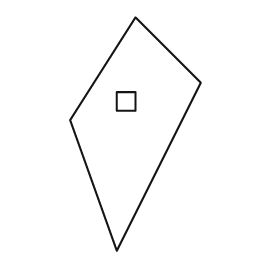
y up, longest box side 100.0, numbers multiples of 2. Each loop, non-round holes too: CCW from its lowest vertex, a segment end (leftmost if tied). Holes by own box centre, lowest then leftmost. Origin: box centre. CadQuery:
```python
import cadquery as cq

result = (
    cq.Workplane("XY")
    .moveTo(-8.0, -50.0)
    .lineTo(28.0, 22.0)
    .lineTo(0.0, 50.0)
    .lineTo(-28.0, 6.0)
    .close()
    .moveTo(-8.0, 10.0)
    .lineTo(0.0, 10.0)
    .lineTo(0.0, 18.0)
    .lineTo(-8.0, 18.0)
    .close()
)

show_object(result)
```